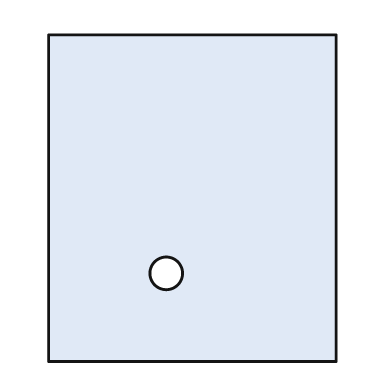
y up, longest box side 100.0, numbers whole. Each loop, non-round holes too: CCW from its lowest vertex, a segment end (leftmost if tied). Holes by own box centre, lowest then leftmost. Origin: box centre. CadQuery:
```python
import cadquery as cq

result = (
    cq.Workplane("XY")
    .moveTo(-44.0, -50.0)
    .lineTo(44.0, -50.0)
    .lineTo(44.0, 50.0)
    .lineTo(-44.0, 50.0)
    .close()
    .moveTo(-8.0, -23.0)
    .circle(5.0)
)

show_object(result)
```